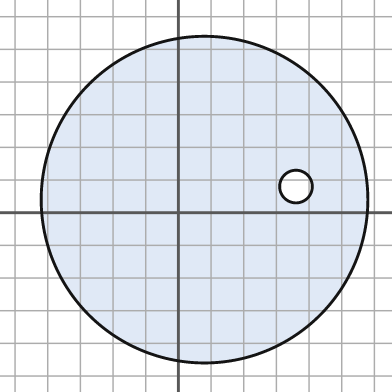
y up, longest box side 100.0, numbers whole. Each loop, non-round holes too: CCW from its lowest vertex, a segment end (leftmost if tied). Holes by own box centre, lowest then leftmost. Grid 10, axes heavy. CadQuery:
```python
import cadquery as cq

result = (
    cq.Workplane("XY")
    .moveTo(8.0, 4.0)
    .circle(50.0)
    .moveTo(36.0, 8.0)
    .circle(5.0)
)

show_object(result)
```